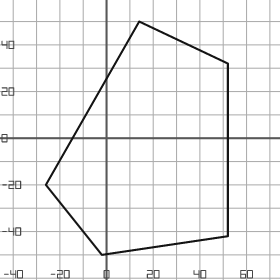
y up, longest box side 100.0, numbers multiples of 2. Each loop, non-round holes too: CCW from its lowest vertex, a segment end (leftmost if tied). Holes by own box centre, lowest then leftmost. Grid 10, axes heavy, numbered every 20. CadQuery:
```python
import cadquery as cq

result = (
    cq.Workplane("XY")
    .moveTo(-2.0, -50.0)
    .lineTo(52.0, -42.0)
    .lineTo(52.0, 32.0)
    .lineTo(14.0, 50.0)
    .lineTo(-26.0, -20.0)
    .close()
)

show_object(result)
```